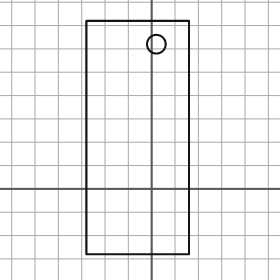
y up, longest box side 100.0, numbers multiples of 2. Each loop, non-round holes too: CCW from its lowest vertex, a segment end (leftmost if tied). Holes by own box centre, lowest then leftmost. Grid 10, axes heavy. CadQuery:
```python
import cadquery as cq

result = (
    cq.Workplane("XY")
    .moveTo(-28.0, -28.0)
    .lineTo(16.0, -28.0)
    .lineTo(16.0, 72.0)
    .lineTo(-28.0, 72.0)
    .close()
    .moveTo(2.0, 62.0)
    .circle(4.0)
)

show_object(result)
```